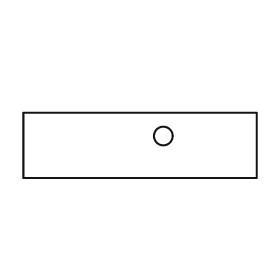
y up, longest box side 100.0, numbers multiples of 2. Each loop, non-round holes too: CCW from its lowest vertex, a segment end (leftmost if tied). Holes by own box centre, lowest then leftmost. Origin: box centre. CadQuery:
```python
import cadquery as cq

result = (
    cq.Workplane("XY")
    .moveTo(-50.0, -14.0)
    .lineTo(50.0, -14.0)
    .lineTo(50.0, 14.0)
    .lineTo(-50.0, 14.0)
    .close()
    .moveTo(10.0, 4.0)
    .circle(4.0)
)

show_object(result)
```